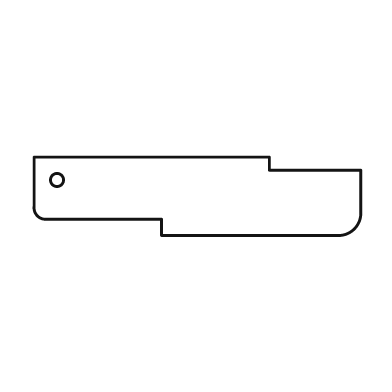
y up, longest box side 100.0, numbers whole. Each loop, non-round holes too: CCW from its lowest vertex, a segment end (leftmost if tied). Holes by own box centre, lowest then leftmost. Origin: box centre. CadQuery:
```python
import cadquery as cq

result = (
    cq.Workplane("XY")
    .moveTo(-11.0, -12.0)
    .lineTo(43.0, -12.0)
    .threePointArc((48.0, -10.0), (50.0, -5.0))
    .lineTo(50.0, 8.0)
    .lineTo(22.0, 8.0)
    .lineTo(22.0, 12.0)
    .lineTo(-50.0, 12.0)
    .lineTo(-50.0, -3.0)
    .threePointArc((-49.0, -6.0), (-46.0, -7.0))
    .lineTo(-11.0, -7.0)
    .close()
    .moveTo(-43.0, 5.0)
    .circle(2.0)
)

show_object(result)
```